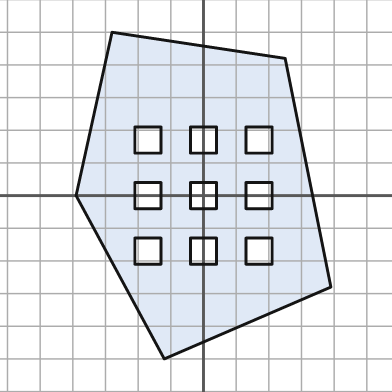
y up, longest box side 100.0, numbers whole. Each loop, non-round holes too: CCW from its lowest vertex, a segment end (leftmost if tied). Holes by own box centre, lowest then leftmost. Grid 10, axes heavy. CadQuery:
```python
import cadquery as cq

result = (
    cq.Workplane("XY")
    .moveTo(-12.0, -50.0)
    .lineTo(39.0, -28.0)
    .lineTo(25.0, 42.0)
    .lineTo(-28.0, 50.0)
    .lineTo(-39.0, 0.0)
    .close()
    .moveTo(-21.0, -21.0)
    .lineTo(-13.0, -21.0)
    .lineTo(-13.0, -13.0)
    .lineTo(-21.0, -13.0)
    .close()
    .moveTo(-4.0, -21.0)
    .lineTo(4.0, -21.0)
    .lineTo(4.0, -13.0)
    .lineTo(-4.0, -13.0)
    .close()
    .moveTo(13.0, -21.0)
    .lineTo(21.0, -21.0)
    .lineTo(21.0, -13.0)
    .lineTo(13.0, -13.0)
    .close()
    .moveTo(-21.0, -4.0)
    .lineTo(-13.0, -4.0)
    .lineTo(-13.0, 4.0)
    .lineTo(-21.0, 4.0)
    .close()
    .moveTo(-4.0, -4.0)
    .lineTo(4.0, -4.0)
    .lineTo(4.0, 4.0)
    .lineTo(-4.0, 4.0)
    .close()
    .moveTo(13.0, -4.0)
    .lineTo(21.0, -4.0)
    .lineTo(21.0, 4.0)
    .lineTo(13.0, 4.0)
    .close()
    .moveTo(-21.0, 13.0)
    .lineTo(-13.0, 13.0)
    .lineTo(-13.0, 21.0)
    .lineTo(-21.0, 21.0)
    .close()
    .moveTo(-4.0, 13.0)
    .lineTo(4.0, 13.0)
    .lineTo(4.0, 21.0)
    .lineTo(-4.0, 21.0)
    .close()
    .moveTo(13.0, 13.0)
    .lineTo(21.0, 13.0)
    .lineTo(21.0, 21.0)
    .lineTo(13.0, 21.0)
    .close()
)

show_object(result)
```